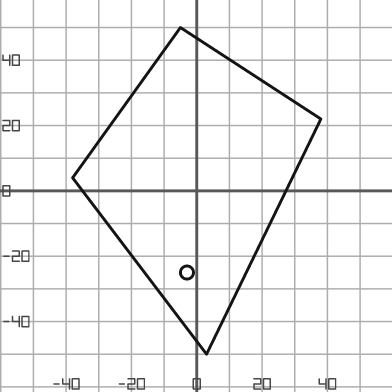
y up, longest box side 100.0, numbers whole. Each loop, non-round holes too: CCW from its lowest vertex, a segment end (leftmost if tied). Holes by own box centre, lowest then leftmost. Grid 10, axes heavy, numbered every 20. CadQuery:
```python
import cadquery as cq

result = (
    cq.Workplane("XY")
    .moveTo(3.0, -50.0)
    .lineTo(38.0, 22.0)
    .lineTo(-5.0, 50.0)
    .lineTo(-38.0, 4.0)
    .close()
    .moveTo(-3.0, -25.0)
    .circle(2.0)
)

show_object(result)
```